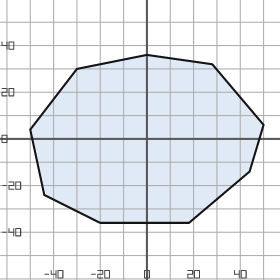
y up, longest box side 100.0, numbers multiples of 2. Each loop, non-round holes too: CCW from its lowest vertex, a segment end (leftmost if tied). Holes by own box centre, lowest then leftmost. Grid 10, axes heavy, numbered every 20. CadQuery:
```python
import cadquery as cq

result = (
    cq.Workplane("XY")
    .moveTo(-20.0, -36.0)
    .lineTo(18.0, -36.0)
    .lineTo(44.0, -14.0)
    .lineTo(50.0, 6.0)
    .lineTo(28.0, 32.0)
    .lineTo(0.0, 36.0)
    .lineTo(-30.0, 30.0)
    .lineTo(-50.0, 4.0)
    .lineTo(-44.0, -24.0)
    .close()
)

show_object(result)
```